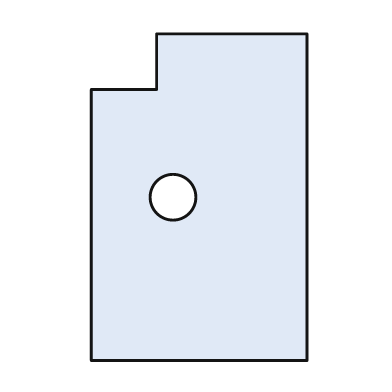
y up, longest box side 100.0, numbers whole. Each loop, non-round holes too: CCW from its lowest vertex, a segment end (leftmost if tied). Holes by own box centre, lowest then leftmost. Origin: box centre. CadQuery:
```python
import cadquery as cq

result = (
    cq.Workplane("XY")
    .moveTo(-33.0, -50.0)
    .lineTo(33.0, -50.0)
    .lineTo(33.0, 50.0)
    .lineTo(-13.0, 50.0)
    .lineTo(-13.0, 33.0)
    .lineTo(-33.0, 33.0)
    .close()
    .moveTo(-8.0, 0.0)
    .circle(7.0)
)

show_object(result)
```